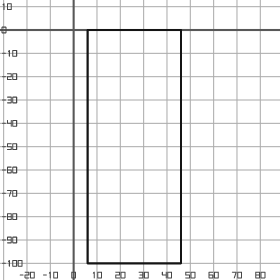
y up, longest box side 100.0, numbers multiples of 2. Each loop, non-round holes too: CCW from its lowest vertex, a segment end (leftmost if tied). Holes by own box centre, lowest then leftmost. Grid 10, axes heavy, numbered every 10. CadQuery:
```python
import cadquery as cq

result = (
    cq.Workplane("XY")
    .moveTo(6.0, -100.0)
    .lineTo(46.0, -100.0)
    .lineTo(46.0, 0.0)
    .lineTo(6.0, 0.0)
    .close()
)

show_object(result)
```